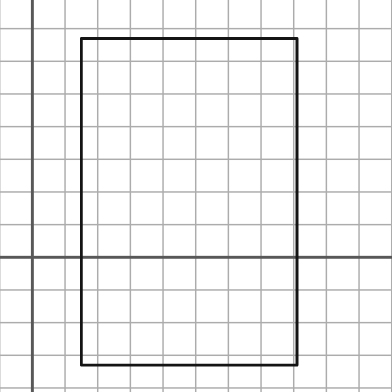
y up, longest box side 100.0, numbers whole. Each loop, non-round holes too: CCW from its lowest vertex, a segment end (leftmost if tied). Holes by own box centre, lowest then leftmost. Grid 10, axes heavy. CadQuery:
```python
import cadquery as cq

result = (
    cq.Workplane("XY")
    .moveTo(15.0, -33.0)
    .lineTo(81.0, -33.0)
    .lineTo(81.0, 67.0)
    .lineTo(15.0, 67.0)
    .close()
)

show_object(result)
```